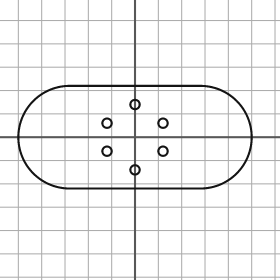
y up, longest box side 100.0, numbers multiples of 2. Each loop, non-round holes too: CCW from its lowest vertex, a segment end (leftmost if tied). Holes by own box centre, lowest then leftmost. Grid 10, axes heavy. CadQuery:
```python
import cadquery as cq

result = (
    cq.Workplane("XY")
    .moveTo(-28.0, -22.0)
    .lineTo(28.0, -22.0)
    .threePointArc((50.0, 0.0), (28.0, 22.0))
    .lineTo(-28.0, 22.0)
    .threePointArc((-50.0, 0.0), (-28.0, -22.0))
    .close()
    .moveTo(0.0, -14.0)
    .circle(2.0)
    .moveTo(-12.0, -6.0)
    .circle(2.0)
    .moveTo(12.0, -6.0)
    .circle(2.0)
    .moveTo(-12.0, 6.0)
    .circle(2.0)
    .moveTo(12.0, 6.0)
    .circle(2.0)
    .moveTo(0.0, 14.0)
    .circle(2.0)
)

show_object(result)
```